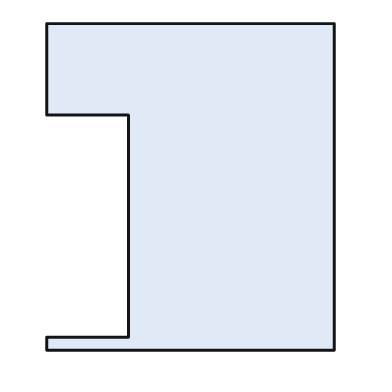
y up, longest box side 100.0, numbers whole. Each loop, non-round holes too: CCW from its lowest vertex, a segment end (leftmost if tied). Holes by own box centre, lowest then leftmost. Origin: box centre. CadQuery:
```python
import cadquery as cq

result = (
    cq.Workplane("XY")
    .moveTo(-44.0, -50.0)
    .lineTo(44.0, -50.0)
    .lineTo(44.0, 50.0)
    .lineTo(-44.0, 50.0)
    .lineTo(-44.0, 22.0)
    .lineTo(-19.0, 22.0)
    .lineTo(-19.0, -46.0)
    .lineTo(-44.0, -46.0)
    .close()
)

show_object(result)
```